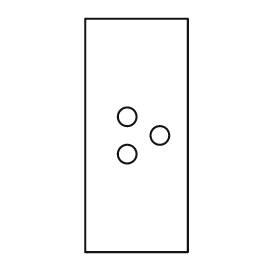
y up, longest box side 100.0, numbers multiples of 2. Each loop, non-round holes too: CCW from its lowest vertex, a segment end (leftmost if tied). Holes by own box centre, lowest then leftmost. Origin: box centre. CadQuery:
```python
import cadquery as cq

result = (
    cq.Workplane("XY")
    .moveTo(-22.0, -50.0)
    .lineTo(22.0, -50.0)
    .lineTo(22.0, 50.0)
    .lineTo(-22.0, 50.0)
    .close()
    .moveTo(-4.0, -8.0)
    .circle(4.0)
    .moveTo(10.0, 0.0)
    .circle(4.0)
    .moveTo(-4.0, 8.0)
    .circle(4.0)
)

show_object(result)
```